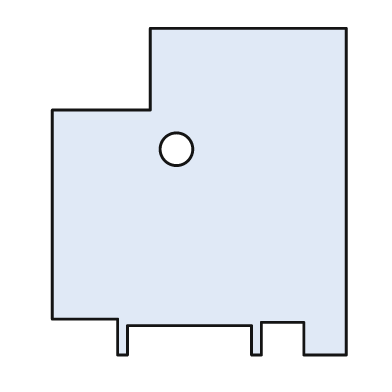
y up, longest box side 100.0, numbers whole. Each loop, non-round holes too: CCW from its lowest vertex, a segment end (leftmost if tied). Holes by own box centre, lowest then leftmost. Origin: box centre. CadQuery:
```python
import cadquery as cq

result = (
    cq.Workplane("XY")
    .moveTo(-25.0, -50.0)
    .lineTo(-22.0, -50.0)
    .lineTo(-22.0, -41.0)
    .lineTo(16.0, -41.0)
    .lineTo(16.0, -50.0)
    .lineTo(19.0, -50.0)
    .lineTo(19.0, -40.0)
    .lineTo(32.0, -40.0)
    .lineTo(32.0, -50.0)
    .lineTo(45.0, -50.0)
    .lineTo(45.0, 50.0)
    .lineTo(-15.0, 50.0)
    .lineTo(-15.0, 25.0)
    .lineTo(-45.0, 25.0)
    .lineTo(-45.0, -39.0)
    .lineTo(-25.0, -39.0)
    .close()
    .moveTo(-7.0, 13.0)
    .circle(5.0)
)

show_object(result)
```